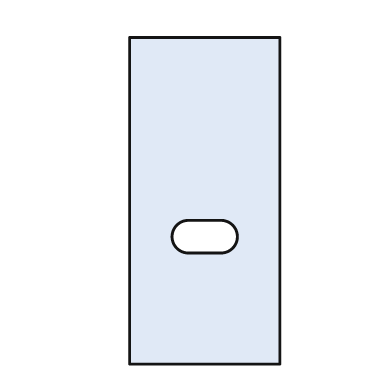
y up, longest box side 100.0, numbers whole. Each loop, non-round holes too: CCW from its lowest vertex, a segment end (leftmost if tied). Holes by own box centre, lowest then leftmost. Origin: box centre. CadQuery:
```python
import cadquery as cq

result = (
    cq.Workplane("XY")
    .moveTo(-23.0, -50.0)
    .lineTo(23.0, -50.0)
    .lineTo(23.0, 50.0)
    .lineTo(-23.0, 50.0)
    .close()
    .moveTo(-5.0, -16.0)
    .lineTo(5.0, -16.0)
    .threePointArc((10.0, -11.0), (5.0, -6.0))
    .lineTo(-5.0, -6.0)
    .threePointArc((-10.0, -11.0), (-5.0, -16.0))
    .close()
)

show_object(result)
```